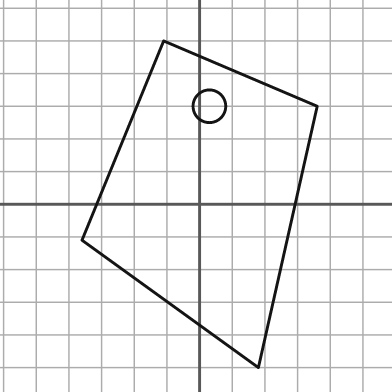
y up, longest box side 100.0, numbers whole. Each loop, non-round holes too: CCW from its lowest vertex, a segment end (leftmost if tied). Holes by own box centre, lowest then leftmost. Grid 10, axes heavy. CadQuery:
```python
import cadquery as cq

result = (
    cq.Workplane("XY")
    .moveTo(18.0, -50.0)
    .lineTo(36.0, 30.0)
    .lineTo(-11.0, 50.0)
    .lineTo(-36.0, -11.0)
    .close()
    .moveTo(3.0, 30.0)
    .circle(5.0)
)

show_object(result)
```